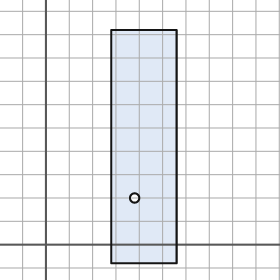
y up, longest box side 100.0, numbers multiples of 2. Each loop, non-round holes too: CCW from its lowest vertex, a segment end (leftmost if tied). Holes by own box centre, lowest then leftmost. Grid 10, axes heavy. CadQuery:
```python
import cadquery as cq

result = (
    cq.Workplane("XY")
    .moveTo(28.0, -8.0)
    .lineTo(56.0, -8.0)
    .lineTo(56.0, 92.0)
    .lineTo(28.0, 92.0)
    .close()
    .moveTo(38.0, 20.0)
    .circle(2.0)
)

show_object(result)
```